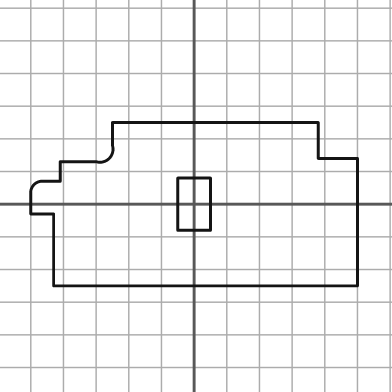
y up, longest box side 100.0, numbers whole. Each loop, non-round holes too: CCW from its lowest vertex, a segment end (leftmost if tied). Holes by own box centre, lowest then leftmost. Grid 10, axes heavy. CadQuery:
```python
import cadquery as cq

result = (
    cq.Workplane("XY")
    .moveTo(-43.0, -25.0)
    .lineTo(50.0, -25.0)
    .lineTo(50.0, 14.0)
    .lineTo(38.0, 14.0)
    .lineTo(38.0, 25.0)
    .lineTo(-25.0, 25.0)
    .lineTo(-25.0, 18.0)
    .threePointArc((-26.0, 14.0), (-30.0, 13.0))
    .lineTo(-41.0, 13.0)
    .lineTo(-41.0, 7.0)
    .lineTo(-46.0, 7.0)
    .threePointArc((-49.0, 6.0), (-50.0, 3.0))
    .lineTo(-50.0, -3.0)
    .lineTo(-43.0, -3.0)
    .close()
    .moveTo(-5.0, -8.0)
    .lineTo(5.0, -8.0)
    .lineTo(5.0, 8.0)
    .lineTo(-5.0, 8.0)
    .close()
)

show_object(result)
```